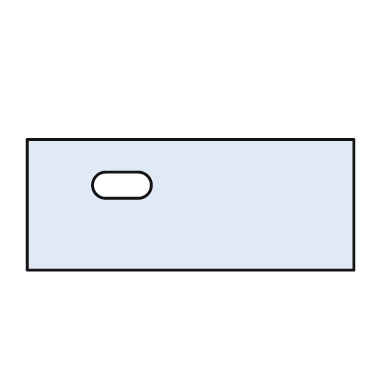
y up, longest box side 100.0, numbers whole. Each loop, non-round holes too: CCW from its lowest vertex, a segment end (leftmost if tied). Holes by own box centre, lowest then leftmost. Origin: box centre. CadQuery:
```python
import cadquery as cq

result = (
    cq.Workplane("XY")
    .moveTo(-50.0, -20.0)
    .lineTo(50.0, -20.0)
    .lineTo(50.0, 20.0)
    .lineTo(-50.0, 20.0)
    .close()
    .moveTo(-26.0, 2.0)
    .lineTo(-16.0, 2.0)
    .threePointArc((-12.0, 6.0), (-16.0, 10.0))
    .lineTo(-26.0, 10.0)
    .threePointArc((-30.0, 6.0), (-26.0, 2.0))
    .close()
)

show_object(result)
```